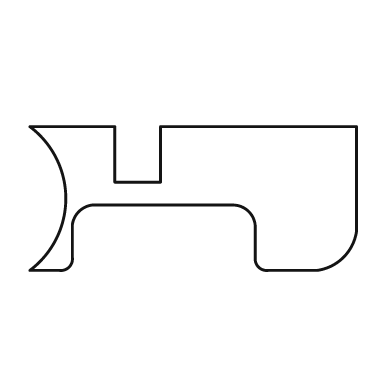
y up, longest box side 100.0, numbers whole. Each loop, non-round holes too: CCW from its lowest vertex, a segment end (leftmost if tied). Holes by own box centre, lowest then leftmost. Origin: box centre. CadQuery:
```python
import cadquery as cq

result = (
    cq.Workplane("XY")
    .moveTo(-50.0, -22.0)
    .lineTo(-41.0, -22.0)
    .threePointArc((-38.0, -21.0), (-37.0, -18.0))
    .lineTo(-37.0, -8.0)
    .threePointArc((-35.0, -4.0), (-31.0, -2.0))
    .lineTo(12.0, -2.0)
    .threePointArc((17.0, -4.0), (19.0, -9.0))
    .lineTo(19.0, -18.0)
    .threePointArc((20.0, -21.0), (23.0, -22.0))
    .lineTo(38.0, -22.0)
    .threePointArc((46.0, -18.0), (50.0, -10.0))
    .lineTo(50.0, 22.0)
    .lineTo(-10.0, 22.0)
    .lineTo(-10.0, 5.0)
    .lineTo(-24.0, 5.0)
    .lineTo(-24.0, 22.0)
    .lineTo(-50.0, 22.0)
    .threePointArc((-39.0, 0.0), (-50.0, -22.0))
    .close()
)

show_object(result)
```